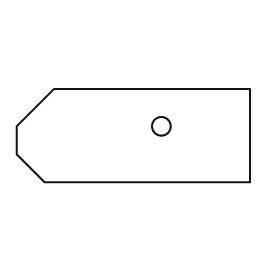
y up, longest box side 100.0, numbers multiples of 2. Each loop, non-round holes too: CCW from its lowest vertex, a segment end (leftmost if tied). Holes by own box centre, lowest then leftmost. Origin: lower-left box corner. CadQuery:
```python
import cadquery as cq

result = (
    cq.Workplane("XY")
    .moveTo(12.0, 0.0)
    .lineTo(100.0, 0.0)
    .lineTo(100.0, 40.0)
    .lineTo(16.0, 40.0)
    .lineTo(0.0, 24.0)
    .lineTo(0.0, 12.0)
    .close()
    .moveTo(62.0, 24.0)
    .circle(4.0)
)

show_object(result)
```